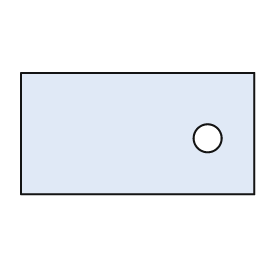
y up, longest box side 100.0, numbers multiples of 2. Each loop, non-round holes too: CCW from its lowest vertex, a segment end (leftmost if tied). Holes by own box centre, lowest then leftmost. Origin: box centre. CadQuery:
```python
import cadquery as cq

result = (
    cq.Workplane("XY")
    .moveTo(-50.0, -26.0)
    .lineTo(50.0, -26.0)
    .lineTo(50.0, 26.0)
    .lineTo(-50.0, 26.0)
    .close()
    .moveTo(30.0, -2.0)
    .circle(6.0)
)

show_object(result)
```